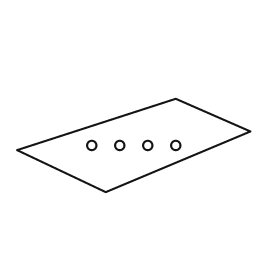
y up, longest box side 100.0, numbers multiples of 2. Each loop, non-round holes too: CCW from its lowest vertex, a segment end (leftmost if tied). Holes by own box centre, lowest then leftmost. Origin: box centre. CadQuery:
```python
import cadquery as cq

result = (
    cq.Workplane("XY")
    .moveTo(-12.0, -20.0)
    .lineTo(50.0, 6.0)
    .lineTo(18.0, 20.0)
    .lineTo(-50.0, -2.0)
    .close()
    .moveTo(-18.0, 0.0)
    .circle(2.0)
    .moveTo(-6.0, 0.0)
    .circle(2.0)
    .moveTo(6.0, 0.0)
    .circle(2.0)
    .moveTo(18.0, 0.0)
    .circle(2.0)
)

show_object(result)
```